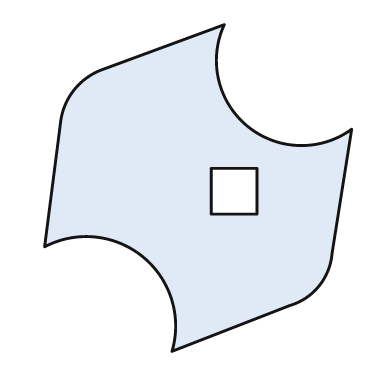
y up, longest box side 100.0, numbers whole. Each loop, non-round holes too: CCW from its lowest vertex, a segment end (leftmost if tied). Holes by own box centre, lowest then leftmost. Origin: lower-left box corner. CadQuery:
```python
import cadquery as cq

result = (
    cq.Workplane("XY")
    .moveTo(39.0, 0.0)
    .lineTo(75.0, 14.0)
    .threePointArc((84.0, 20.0), (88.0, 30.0))
    .lineTo(94.0, 68.0)
    .threePointArc((62.0, 69.0), (55.0, 100.0))
    .lineTo(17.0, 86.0)
    .threePointArc((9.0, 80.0), (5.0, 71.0))
    .lineTo(0.0, 32.0)
    .threePointArc((30.0, 29.0), (39.0, 0.0))
    .close()
    .moveTo(51.0, 42.0)
    .lineTo(65.0, 42.0)
    .lineTo(65.0, 56.0)
    .lineTo(51.0, 56.0)
    .close()
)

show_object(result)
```